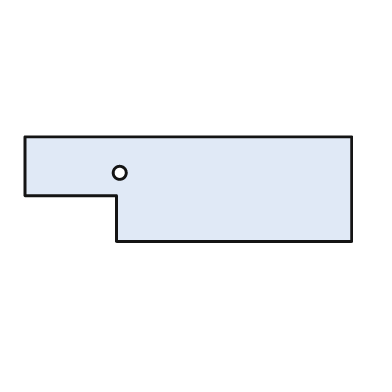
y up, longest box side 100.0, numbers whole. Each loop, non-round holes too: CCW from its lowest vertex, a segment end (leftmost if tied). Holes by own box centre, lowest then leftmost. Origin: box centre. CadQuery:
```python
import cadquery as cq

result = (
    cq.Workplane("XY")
    .moveTo(-22.0, -16.0)
    .lineTo(50.0, -16.0)
    .lineTo(50.0, 16.0)
    .lineTo(-50.0, 16.0)
    .lineTo(-50.0, -2.0)
    .lineTo(-22.0, -2.0)
    .close()
    .moveTo(-21.0, 5.0)
    .circle(2.0)
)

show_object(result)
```